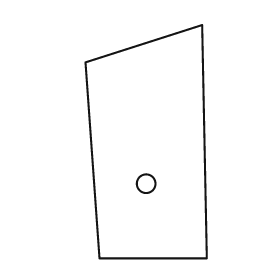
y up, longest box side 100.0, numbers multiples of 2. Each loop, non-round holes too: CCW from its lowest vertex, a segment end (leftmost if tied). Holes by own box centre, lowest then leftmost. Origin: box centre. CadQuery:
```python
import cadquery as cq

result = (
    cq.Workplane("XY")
    .moveTo(-20.0, -50.0)
    .lineTo(26.0, -50.0)
    .lineTo(24.0, 50.0)
    .lineTo(-26.0, 34.0)
    .close()
    .moveTo(0.0, -18.0)
    .circle(4.0)
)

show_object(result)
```